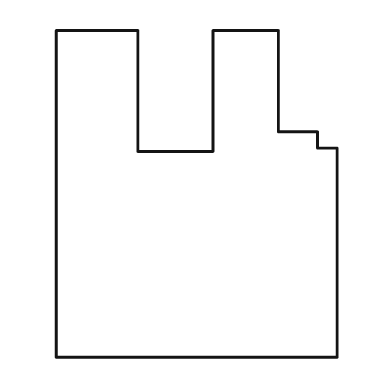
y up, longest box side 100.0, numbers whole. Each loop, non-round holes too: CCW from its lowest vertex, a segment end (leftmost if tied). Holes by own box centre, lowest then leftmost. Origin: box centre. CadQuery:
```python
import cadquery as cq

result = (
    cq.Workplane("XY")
    .moveTo(-43.0, -50.0)
    .lineTo(43.0, -50.0)
    .lineTo(43.0, 14.0)
    .lineTo(37.0, 14.0)
    .lineTo(37.0, 19.0)
    .lineTo(25.0, 19.0)
    .lineTo(25.0, 50.0)
    .lineTo(5.0, 50.0)
    .lineTo(5.0, 13.0)
    .lineTo(-18.0, 13.0)
    .lineTo(-18.0, 50.0)
    .lineTo(-43.0, 50.0)
    .close()
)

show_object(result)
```